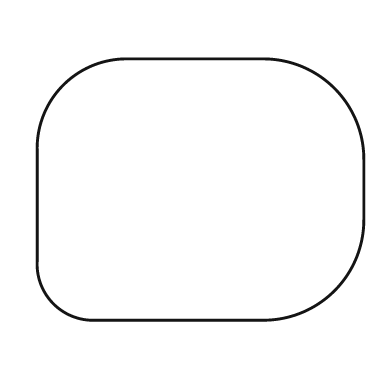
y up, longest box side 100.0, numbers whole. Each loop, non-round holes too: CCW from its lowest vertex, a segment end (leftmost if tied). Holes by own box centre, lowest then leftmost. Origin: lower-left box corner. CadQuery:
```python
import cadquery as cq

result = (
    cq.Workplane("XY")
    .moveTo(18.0, 0.0)
    .lineTo(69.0, 0.0)
    .threePointArc((91.0, 9.0), (100.0, 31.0))
    .lineTo(100.0, 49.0)
    .threePointArc((91.0, 71.0), (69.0, 80.0))
    .lineTo(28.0, 80.0)
    .threePointArc((8.0, 72.0), (0.0, 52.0))
    .lineTo(0.0, 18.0)
    .threePointArc((5.0, 5.0), (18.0, 0.0))
    .close()
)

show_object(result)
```